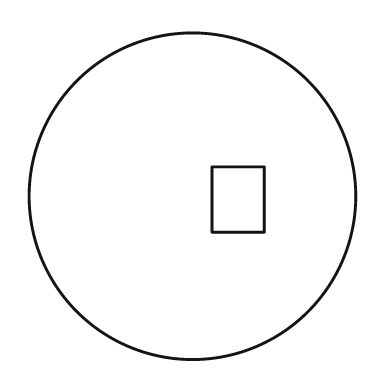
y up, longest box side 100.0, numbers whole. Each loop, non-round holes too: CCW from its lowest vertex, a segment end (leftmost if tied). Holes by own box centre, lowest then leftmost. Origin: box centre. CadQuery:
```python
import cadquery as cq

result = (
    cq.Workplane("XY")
    .moveTo(0.0, 0.0)
    .circle(50.0)
    .moveTo(6.0, -11.0)
    .lineTo(22.0, -11.0)
    .lineTo(22.0, 9.0)
    .lineTo(6.0, 9.0)
    .close()
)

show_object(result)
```